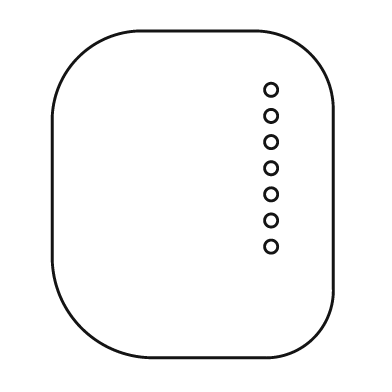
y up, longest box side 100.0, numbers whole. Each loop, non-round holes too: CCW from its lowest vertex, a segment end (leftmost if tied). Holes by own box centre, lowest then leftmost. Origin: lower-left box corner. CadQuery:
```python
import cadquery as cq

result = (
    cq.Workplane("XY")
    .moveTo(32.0, 0.0)
    .lineTo(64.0, 0.0)
    .threePointArc((80.0, 6.0), (86.0, 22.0))
    .lineTo(86.0, 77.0)
    .threePointArc((79.0, 93.0), (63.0, 100.0))
    .lineTo(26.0, 100.0)
    .threePointArc((8.0, 92.0), (0.0, 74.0))
    .lineTo(0.0, 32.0)
    .threePointArc((9.0, 9.0), (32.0, 0.0))
    .close()
    .moveTo(67.0, 34.0)
    .circle(2.0)
    .moveTo(67.0, 42.0)
    .circle(2.0)
    .moveTo(67.0, 50.0)
    .circle(2.0)
    .moveTo(67.0, 58.0)
    .circle(2.0)
    .moveTo(67.0, 66.0)
    .circle(2.0)
    .moveTo(67.0, 74.0)
    .circle(2.0)
    .moveTo(67.0, 82.0)
    .circle(2.0)
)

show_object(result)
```